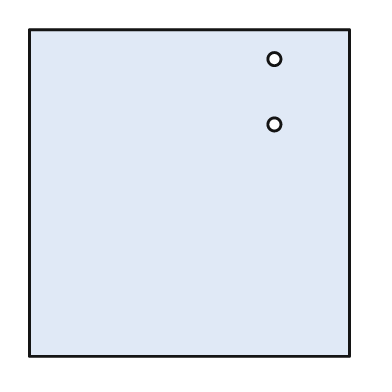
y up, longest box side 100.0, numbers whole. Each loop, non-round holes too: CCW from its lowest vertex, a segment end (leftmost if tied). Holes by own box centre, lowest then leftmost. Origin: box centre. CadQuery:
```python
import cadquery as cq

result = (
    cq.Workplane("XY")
    .moveTo(-49.0, -50.0)
    .lineTo(49.0, -50.0)
    .lineTo(49.0, 50.0)
    .lineTo(-49.0, 50.0)
    .close()
    .moveTo(26.0, 21.0)
    .circle(2.0)
    .moveTo(26.0, 41.0)
    .circle(2.0)
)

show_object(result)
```